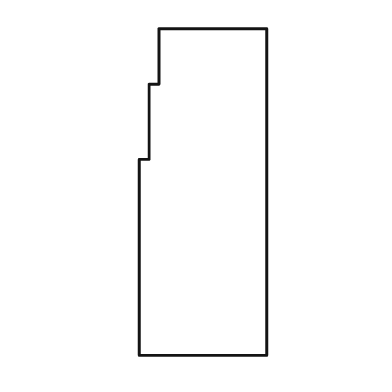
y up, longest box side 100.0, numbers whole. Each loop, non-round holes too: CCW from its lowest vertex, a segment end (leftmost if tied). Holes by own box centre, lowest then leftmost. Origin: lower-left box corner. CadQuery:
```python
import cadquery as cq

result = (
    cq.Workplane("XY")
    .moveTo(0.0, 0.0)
    .lineTo(39.0, 0.0)
    .lineTo(39.0, 100.0)
    .lineTo(6.0, 100.0)
    .lineTo(6.0, 83.0)
    .lineTo(3.0, 83.0)
    .lineTo(3.0, 60.0)
    .lineTo(0.0, 60.0)
    .close()
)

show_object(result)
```